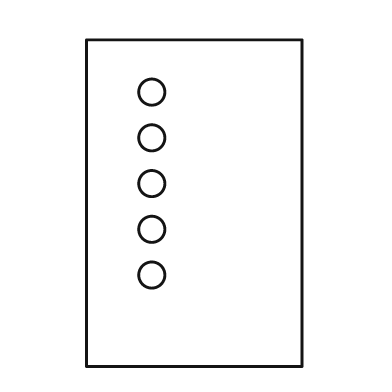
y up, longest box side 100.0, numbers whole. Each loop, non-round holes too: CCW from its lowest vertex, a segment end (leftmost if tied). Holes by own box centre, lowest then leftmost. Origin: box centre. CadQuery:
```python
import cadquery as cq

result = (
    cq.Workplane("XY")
    .moveTo(-33.0, -50.0)
    .lineTo(33.0, -50.0)
    .lineTo(33.0, 50.0)
    .lineTo(-33.0, 50.0)
    .close()
    .moveTo(-13.0, -22.0)
    .circle(4.0)
    .moveTo(-13.0, -8.0)
    .circle(4.0)
    .moveTo(-13.0, 6.0)
    .circle(4.0)
    .moveTo(-13.0, 20.0)
    .circle(4.0)
    .moveTo(-13.0, 34.0)
    .circle(4.0)
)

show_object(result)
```